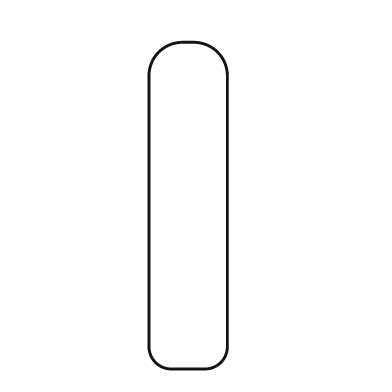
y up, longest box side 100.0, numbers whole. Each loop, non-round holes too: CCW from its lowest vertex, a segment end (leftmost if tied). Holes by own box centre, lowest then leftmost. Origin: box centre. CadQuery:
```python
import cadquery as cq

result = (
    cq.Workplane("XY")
    .moveTo(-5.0, -50.0)
    .lineTo(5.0, -50.0)
    .threePointArc((10.0, -48.0), (12.0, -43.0))
    .lineTo(12.0, 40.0)
    .threePointArc((9.0, 47.0), (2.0, 50.0))
    .lineTo(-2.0, 50.0)
    .threePointArc((-9.0, 47.0), (-12.0, 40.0))
    .lineTo(-12.0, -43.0)
    .threePointArc((-10.0, -48.0), (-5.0, -50.0))
    .close()
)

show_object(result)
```